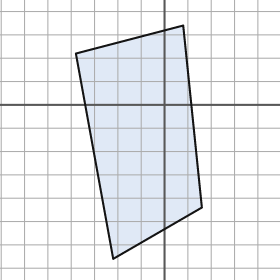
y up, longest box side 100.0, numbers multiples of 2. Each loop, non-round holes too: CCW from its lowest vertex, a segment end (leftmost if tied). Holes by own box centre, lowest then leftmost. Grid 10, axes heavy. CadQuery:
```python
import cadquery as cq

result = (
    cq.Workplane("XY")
    .moveTo(-22.0, -66.0)
    .lineTo(16.0, -44.0)
    .lineTo(8.0, 34.0)
    .lineTo(-38.0, 22.0)
    .close()
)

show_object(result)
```